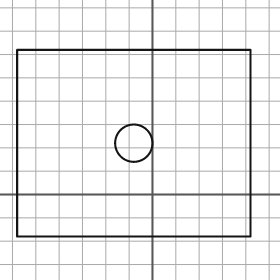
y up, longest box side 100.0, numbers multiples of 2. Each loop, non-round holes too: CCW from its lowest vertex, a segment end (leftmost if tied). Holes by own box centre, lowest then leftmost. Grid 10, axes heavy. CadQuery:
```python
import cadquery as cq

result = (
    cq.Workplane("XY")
    .moveTo(-58.0, -18.0)
    .lineTo(42.0, -18.0)
    .lineTo(42.0, 62.0)
    .lineTo(-58.0, 62.0)
    .close()
    .moveTo(-8.0, 22.0)
    .circle(8.0)
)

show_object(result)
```